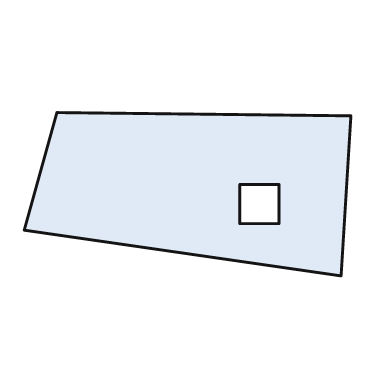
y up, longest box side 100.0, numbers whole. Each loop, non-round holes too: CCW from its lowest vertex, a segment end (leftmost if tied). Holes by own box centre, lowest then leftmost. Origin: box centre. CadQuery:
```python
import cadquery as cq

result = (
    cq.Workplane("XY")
    .moveTo(47.0, -25.0)
    .lineTo(50.0, 24.0)
    .lineTo(-40.0, 25.0)
    .lineTo(-50.0, -11.0)
    .close()
    .moveTo(16.0, -9.0)
    .lineTo(28.0, -9.0)
    .lineTo(28.0, 3.0)
    .lineTo(16.0, 3.0)
    .close()
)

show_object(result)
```